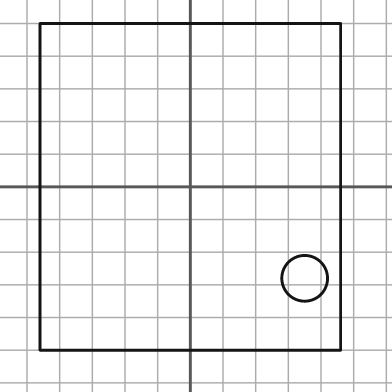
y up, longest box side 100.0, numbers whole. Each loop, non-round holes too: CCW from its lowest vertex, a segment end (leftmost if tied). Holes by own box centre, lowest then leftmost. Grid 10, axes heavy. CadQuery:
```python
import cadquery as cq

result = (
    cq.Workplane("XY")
    .moveTo(-46.0, -50.0)
    .lineTo(46.0, -50.0)
    .lineTo(46.0, 50.0)
    .lineTo(-46.0, 50.0)
    .close()
    .moveTo(35.0, -28.0)
    .circle(7.0)
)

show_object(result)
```